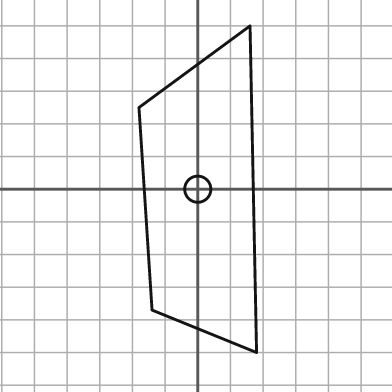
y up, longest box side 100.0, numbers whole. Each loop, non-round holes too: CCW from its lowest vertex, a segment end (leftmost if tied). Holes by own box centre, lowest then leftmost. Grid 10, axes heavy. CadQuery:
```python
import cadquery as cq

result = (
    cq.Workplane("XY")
    .moveTo(18.0, -50.0)
    .lineTo(16.0, 50.0)
    .lineTo(-18.0, 25.0)
    .lineTo(-14.0, -37.0)
    .close()
    .moveTo(0.0, 0.0)
    .circle(4.0)
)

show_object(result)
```